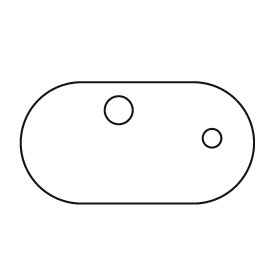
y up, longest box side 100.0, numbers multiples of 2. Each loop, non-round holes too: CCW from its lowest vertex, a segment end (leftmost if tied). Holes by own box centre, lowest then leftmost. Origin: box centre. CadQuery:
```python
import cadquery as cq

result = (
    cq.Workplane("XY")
    .moveTo(-24.0, -26.0)
    .lineTo(24.0, -26.0)
    .threePointArc((50.0, 0.0), (24.0, 26.0))
    .lineTo(-24.0, 26.0)
    .threePointArc((-50.0, 0.0), (-24.0, -26.0))
    .close()
    .moveTo(32.0, 2.0)
    .circle(4.0)
    .moveTo(-8.0, 14.0)
    .circle(6.0)
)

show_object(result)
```